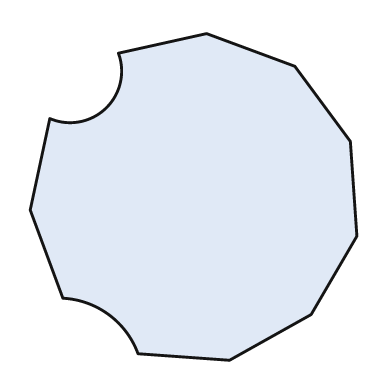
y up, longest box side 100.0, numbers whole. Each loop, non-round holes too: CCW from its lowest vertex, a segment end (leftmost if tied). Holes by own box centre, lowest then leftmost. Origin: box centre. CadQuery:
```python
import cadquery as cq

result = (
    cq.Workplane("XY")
    .moveTo(11.0, -50.0)
    .lineTo(36.0, -36.0)
    .lineTo(50.0, -12.0)
    .lineTo(48.0, 17.0)
    .lineTo(31.0, 40.0)
    .lineTo(4.0, 50.0)
    .lineTo(-23.0, 44.0)
    .threePointArc((-27.0, 27.0), (-44.0, 24.0))
    .lineTo(-50.0, -4.0)
    .lineTo(-40.0, -31.0)
    .threePointArc((-26.0, -36.0), (-17.0, -48.0))
    .close()
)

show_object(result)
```